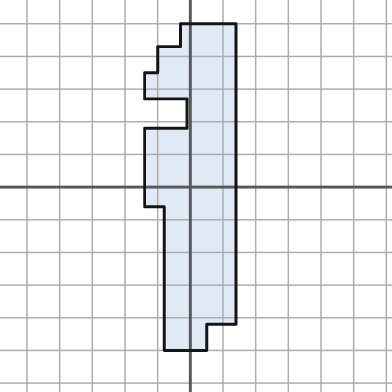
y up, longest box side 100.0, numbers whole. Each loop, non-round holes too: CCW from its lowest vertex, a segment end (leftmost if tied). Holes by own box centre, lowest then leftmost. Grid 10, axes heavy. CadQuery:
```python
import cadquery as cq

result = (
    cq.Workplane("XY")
    .moveTo(-8.0, -50.0)
    .lineTo(5.0, -50.0)
    .lineTo(5.0, -42.0)
    .lineTo(14.0, -42.0)
    .lineTo(14.0, 50.0)
    .lineTo(-3.0, 50.0)
    .lineTo(-3.0, 43.0)
    .lineTo(-10.0, 43.0)
    .lineTo(-10.0, 35.0)
    .lineTo(-14.0, 35.0)
    .lineTo(-14.0, 27.0)
    .lineTo(-1.0, 27.0)
    .lineTo(-1.0, 18.0)
    .lineTo(-14.0, 18.0)
    .lineTo(-14.0, -6.0)
    .lineTo(-8.0, -6.0)
    .close()
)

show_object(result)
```